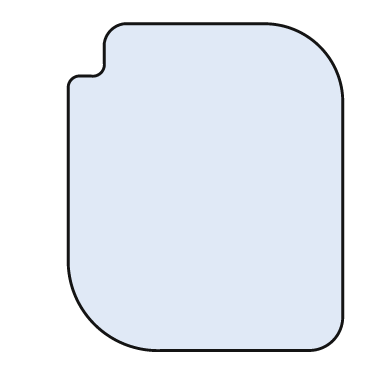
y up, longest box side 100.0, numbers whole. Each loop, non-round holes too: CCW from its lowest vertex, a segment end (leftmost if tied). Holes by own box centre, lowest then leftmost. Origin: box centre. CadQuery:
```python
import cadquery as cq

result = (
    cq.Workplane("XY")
    .moveTo(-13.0, -50.0)
    .lineTo(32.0, -50.0)
    .threePointArc((39.0, -47.0), (42.0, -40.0))
    .lineTo(42.0, 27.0)
    .threePointArc((35.0, 43.0), (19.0, 50.0))
    .lineTo(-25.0, 50.0)
    .threePointArc((-29.0, 48.0), (-31.0, 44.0))
    .lineTo(-31.0, 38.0)
    .threePointArc((-32.0, 35.0), (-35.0, 34.0))
    .lineTo(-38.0, 34.0)
    .threePointArc((-41.0, 33.0), (-42.0, 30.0))
    .lineTo(-42.0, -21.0)
    .threePointArc((-34.0, -42.0), (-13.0, -50.0))
    .close()
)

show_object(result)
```